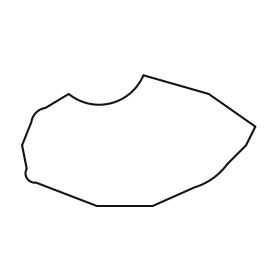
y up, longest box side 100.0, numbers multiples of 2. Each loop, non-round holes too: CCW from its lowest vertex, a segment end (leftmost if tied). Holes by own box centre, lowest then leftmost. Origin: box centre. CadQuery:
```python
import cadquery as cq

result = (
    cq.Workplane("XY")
    .moveTo(-18.0, -28.0)
    .lineTo(6.0, -28.0)
    .lineTo(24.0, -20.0)
    .threePointArc((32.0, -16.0), (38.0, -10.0))
    .lineTo(46.0, -2.0)
    .lineTo(50.0, 6.0)
    .lineTo(30.0, 20.0)
    .lineTo(2.0, 28.0)
    .threePointArc((-12.0, 16.0), (-30.0, 20.0))
    .lineTo(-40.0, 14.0)
    .threePointArc((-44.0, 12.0), (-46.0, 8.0))
    .lineTo(-50.0, -2.0)
    .lineTo(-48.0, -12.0)
    .threePointArc((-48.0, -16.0), (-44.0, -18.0))
    .close()
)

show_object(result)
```